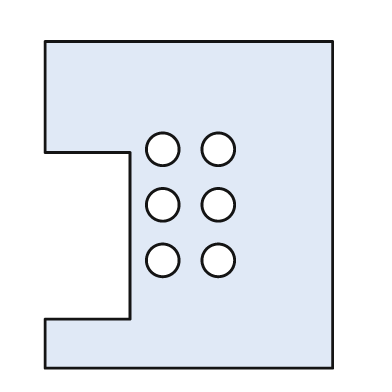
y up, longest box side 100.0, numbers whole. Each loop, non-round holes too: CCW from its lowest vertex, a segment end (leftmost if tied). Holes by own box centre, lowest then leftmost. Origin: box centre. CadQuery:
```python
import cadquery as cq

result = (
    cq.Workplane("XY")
    .moveTo(-44.0, -50.0)
    .lineTo(44.0, -50.0)
    .lineTo(44.0, 50.0)
    .lineTo(-44.0, 50.0)
    .lineTo(-44.0, 16.0)
    .lineTo(-18.0, 16.0)
    .lineTo(-18.0, -35.0)
    .lineTo(-44.0, -35.0)
    .close()
    .moveTo(-8.0, -17.0)
    .circle(5.0)
    .moveTo(9.0, -17.0)
    .circle(5.0)
    .moveTo(-8.0, 0.0)
    .circle(5.0)
    .moveTo(9.0, 0.0)
    .circle(5.0)
    .moveTo(-8.0, 17.0)
    .circle(5.0)
    .moveTo(9.0, 17.0)
    .circle(5.0)
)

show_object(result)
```